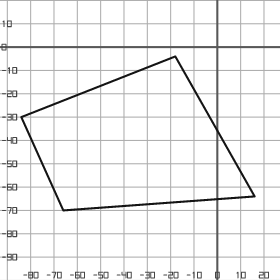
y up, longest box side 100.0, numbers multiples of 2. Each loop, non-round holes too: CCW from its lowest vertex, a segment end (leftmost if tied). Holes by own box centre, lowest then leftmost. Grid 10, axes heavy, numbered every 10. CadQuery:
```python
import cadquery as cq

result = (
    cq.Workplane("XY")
    .moveTo(-66.0, -70.0)
    .lineTo(16.0, -64.0)
    .lineTo(-18.0, -4.0)
    .lineTo(-84.0, -30.0)
    .close()
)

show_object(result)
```